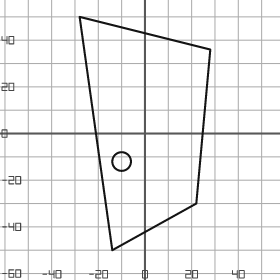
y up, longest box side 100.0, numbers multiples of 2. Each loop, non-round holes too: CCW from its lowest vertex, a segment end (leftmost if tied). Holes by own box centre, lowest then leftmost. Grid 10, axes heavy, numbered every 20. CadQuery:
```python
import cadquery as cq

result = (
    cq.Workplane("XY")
    .moveTo(-14.0, -50.0)
    .lineTo(22.0, -30.0)
    .lineTo(28.0, 36.0)
    .lineTo(-28.0, 50.0)
    .close()
    .moveTo(-10.0, -12.0)
    .circle(4.0)
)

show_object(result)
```